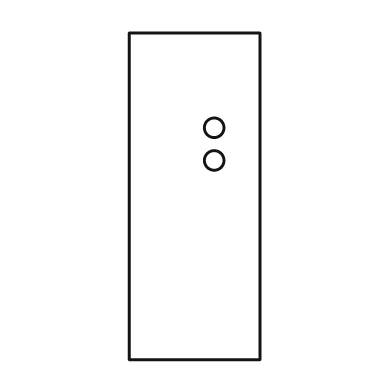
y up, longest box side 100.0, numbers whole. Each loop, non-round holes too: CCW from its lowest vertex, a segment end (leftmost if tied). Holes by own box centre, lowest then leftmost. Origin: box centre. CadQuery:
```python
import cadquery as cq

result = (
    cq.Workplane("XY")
    .moveTo(-20.0, -50.0)
    .lineTo(20.0, -50.0)
    .lineTo(20.0, 50.0)
    .lineTo(-20.0, 50.0)
    .close()
    .moveTo(6.0, 11.0)
    .circle(3.0)
    .moveTo(6.0, 21.0)
    .circle(3.0)
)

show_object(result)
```